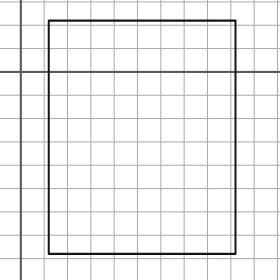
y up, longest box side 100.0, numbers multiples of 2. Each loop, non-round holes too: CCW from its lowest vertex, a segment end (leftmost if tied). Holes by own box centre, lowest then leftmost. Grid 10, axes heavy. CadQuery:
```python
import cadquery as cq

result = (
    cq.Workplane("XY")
    .moveTo(12.0, -78.0)
    .lineTo(92.0, -78.0)
    .lineTo(92.0, 22.0)
    .lineTo(12.0, 22.0)
    .close()
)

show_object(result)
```